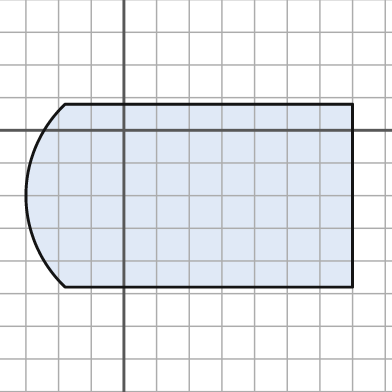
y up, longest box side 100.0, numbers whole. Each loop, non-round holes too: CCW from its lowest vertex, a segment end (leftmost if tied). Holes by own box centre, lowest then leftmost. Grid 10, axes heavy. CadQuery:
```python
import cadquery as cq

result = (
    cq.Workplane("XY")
    .moveTo(-18.0, -48.0)
    .lineTo(70.0, -48.0)
    .lineTo(70.0, 8.0)
    .lineTo(-18.0, 8.0)
    .threePointArc((-30.0, -20.0), (-18.0, -48.0))
    .close()
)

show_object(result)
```